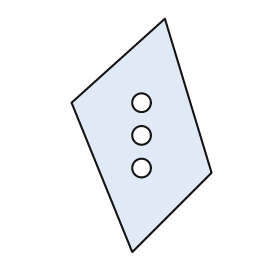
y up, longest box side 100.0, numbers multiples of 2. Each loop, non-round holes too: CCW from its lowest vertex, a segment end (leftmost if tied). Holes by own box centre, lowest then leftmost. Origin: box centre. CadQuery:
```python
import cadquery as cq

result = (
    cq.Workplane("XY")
    .moveTo(-4.0, -50.0)
    .lineTo(30.0, -16.0)
    .lineTo(10.0, 50.0)
    .lineTo(-30.0, 14.0)
    .close()
    .moveTo(0.0, -14.0)
    .circle(4.0)
    .moveTo(0.0, 0.0)
    .circle(4.0)
    .moveTo(0.0, 14.0)
    .circle(4.0)
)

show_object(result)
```